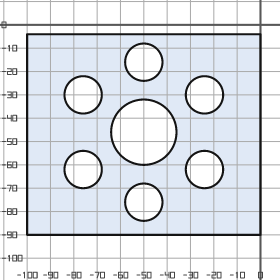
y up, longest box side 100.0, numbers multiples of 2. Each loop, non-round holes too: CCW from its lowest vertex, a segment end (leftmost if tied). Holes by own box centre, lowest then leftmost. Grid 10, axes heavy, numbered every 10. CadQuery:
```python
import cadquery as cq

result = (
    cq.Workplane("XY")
    .moveTo(-100.0, -90.0)
    .lineTo(0.0, -90.0)
    .lineTo(0.0, -4.0)
    .lineTo(-100.0, -4.0)
    .close()
    .moveTo(-50.0, -76.0)
    .circle(8.0)
    .moveTo(-76.0, -62.0)
    .circle(8.0)
    .moveTo(-24.0, -62.0)
    .circle(8.0)
    .moveTo(-50.0, -46.0)
    .circle(14.0)
    .moveTo(-76.0, -30.0)
    .circle(8.0)
    .moveTo(-24.0, -30.0)
    .circle(8.0)
    .moveTo(-50.0, -16.0)
    .circle(8.0)
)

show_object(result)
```